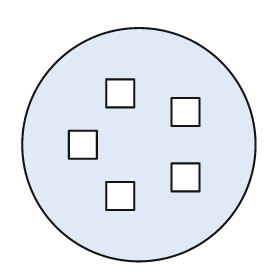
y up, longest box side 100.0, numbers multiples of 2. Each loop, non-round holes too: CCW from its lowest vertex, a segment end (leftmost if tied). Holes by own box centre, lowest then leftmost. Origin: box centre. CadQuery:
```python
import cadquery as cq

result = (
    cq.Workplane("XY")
    .moveTo(0.0, 0.0)
    .circle(50.0)
    .moveTo(-14.0, -28.0)
    .lineTo(-2.0, -28.0)
    .lineTo(-2.0, -16.0)
    .lineTo(-14.0, -16.0)
    .close()
    .moveTo(14.0, -20.0)
    .lineTo(26.0, -20.0)
    .lineTo(26.0, -8.0)
    .lineTo(14.0, -8.0)
    .close()
    .moveTo(-30.0, -6.0)
    .lineTo(-18.0, -6.0)
    .lineTo(-18.0, 6.0)
    .lineTo(-30.0, 6.0)
    .close()
    .moveTo(14.0, 8.0)
    .lineTo(26.0, 8.0)
    .lineTo(26.0, 20.0)
    .lineTo(14.0, 20.0)
    .close()
    .moveTo(-14.0, 16.0)
    .lineTo(-2.0, 16.0)
    .lineTo(-2.0, 28.0)
    .lineTo(-14.0, 28.0)
    .close()
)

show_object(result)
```